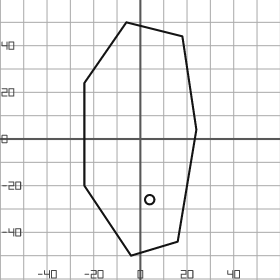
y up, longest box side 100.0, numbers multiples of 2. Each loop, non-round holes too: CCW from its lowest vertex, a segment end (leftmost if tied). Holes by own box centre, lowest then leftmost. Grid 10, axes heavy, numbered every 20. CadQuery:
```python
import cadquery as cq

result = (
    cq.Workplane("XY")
    .moveTo(-4.0, -50.0)
    .lineTo(16.0, -44.0)
    .lineTo(24.0, 4.0)
    .lineTo(18.0, 44.0)
    .lineTo(-6.0, 50.0)
    .lineTo(-24.0, 24.0)
    .lineTo(-24.0, -20.0)
    .close()
    .moveTo(4.0, -26.0)
    .circle(2.0)
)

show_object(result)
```